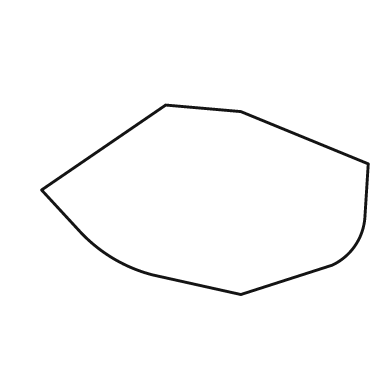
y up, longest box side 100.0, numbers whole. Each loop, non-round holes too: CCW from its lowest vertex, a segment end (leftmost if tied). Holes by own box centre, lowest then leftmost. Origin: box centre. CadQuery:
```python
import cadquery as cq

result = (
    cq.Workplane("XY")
    .moveTo(11.0, -29.0)
    .lineTo(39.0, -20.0)
    .threePointArc((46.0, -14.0), (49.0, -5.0))
    .lineTo(50.0, 11.0)
    .lineTo(11.0, 27.0)
    .lineTo(-12.0, 29.0)
    .lineTo(-50.0, 3.0)
    .lineTo(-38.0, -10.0)
    .threePointArc((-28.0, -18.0), (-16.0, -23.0))
    .close()
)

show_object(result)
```